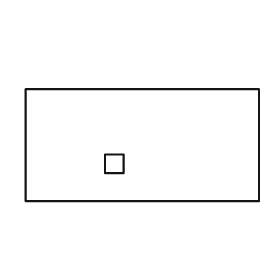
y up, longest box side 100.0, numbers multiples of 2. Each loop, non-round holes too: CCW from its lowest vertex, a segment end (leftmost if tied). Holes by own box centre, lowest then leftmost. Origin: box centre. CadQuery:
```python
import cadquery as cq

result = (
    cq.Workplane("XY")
    .moveTo(-50.0, -24.0)
    .lineTo(50.0, -24.0)
    .lineTo(50.0, 24.0)
    .lineTo(-50.0, 24.0)
    .close()
    .moveTo(-16.0, -12.0)
    .lineTo(-8.0, -12.0)
    .lineTo(-8.0, -4.0)
    .lineTo(-16.0, -4.0)
    .close()
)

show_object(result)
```